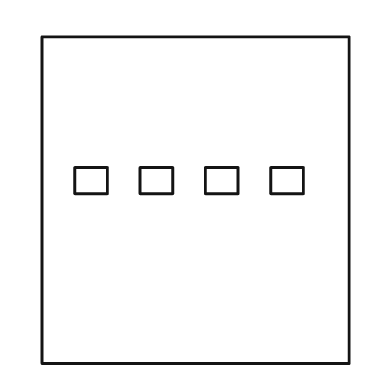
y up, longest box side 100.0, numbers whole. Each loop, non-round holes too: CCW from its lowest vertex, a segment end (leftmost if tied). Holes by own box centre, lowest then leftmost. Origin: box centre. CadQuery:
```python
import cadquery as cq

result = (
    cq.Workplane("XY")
    .moveTo(-47.0, -50.0)
    .lineTo(47.0, -50.0)
    .lineTo(47.0, 50.0)
    .lineTo(-47.0, 50.0)
    .close()
    .moveTo(-37.0, 2.0)
    .lineTo(-27.0, 2.0)
    .lineTo(-27.0, 10.0)
    .lineTo(-37.0, 10.0)
    .close()
    .moveTo(-17.0, 2.0)
    .lineTo(-7.0, 2.0)
    .lineTo(-7.0, 10.0)
    .lineTo(-17.0, 10.0)
    .close()
    .moveTo(3.0, 2.0)
    .lineTo(13.0, 2.0)
    .lineTo(13.0, 10.0)
    .lineTo(3.0, 10.0)
    .close()
    .moveTo(23.0, 2.0)
    .lineTo(33.0, 2.0)
    .lineTo(33.0, 10.0)
    .lineTo(23.0, 10.0)
    .close()
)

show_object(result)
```